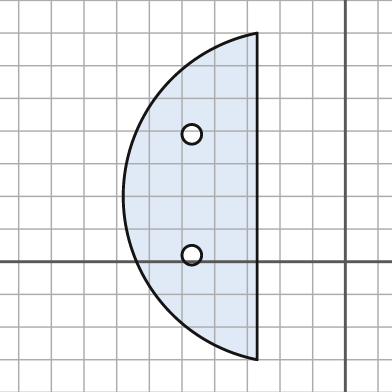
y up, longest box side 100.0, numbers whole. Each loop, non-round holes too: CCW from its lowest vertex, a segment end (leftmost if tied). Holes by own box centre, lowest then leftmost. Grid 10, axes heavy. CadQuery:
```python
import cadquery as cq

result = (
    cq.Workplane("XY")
    .moveTo(-27.0, -30.0)
    .lineTo(-27.0, 70.0)
    .threePointArc((-68.0, 20.0), (-27.0, -30.0))
    .close()
    .moveTo(-47.0, 2.0)
    .circle(3.0)
    .moveTo(-47.0, 39.0)
    .circle(3.0)
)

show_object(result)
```